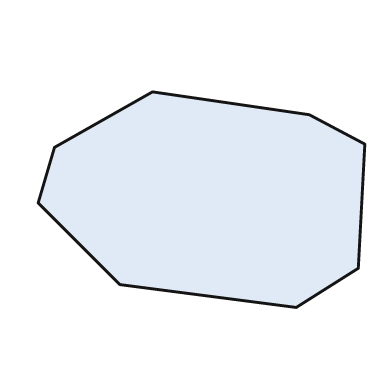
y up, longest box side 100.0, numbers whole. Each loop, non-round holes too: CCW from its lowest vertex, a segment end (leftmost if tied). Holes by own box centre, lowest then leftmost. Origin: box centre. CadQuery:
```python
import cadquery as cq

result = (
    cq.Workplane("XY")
    .moveTo(29.0, -33.0)
    .lineTo(48.0, -21.0)
    .lineTo(50.0, 17.0)
    .lineTo(33.0, 26.0)
    .lineTo(-15.0, 33.0)
    .lineTo(-45.0, 16.0)
    .lineTo(-50.0, -1.0)
    .lineTo(-25.0, -26.0)
    .close()
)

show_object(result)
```